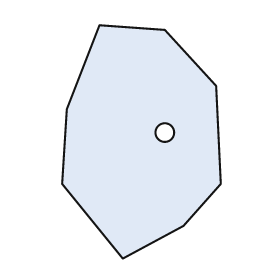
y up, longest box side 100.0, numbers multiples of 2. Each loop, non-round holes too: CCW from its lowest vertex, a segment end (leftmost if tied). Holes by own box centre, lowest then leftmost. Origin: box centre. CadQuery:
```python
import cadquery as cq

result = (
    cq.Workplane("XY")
    .moveTo(-8.0, -50.0)
    .lineTo(18.0, -36.0)
    .lineTo(34.0, -18.0)
    .lineTo(32.0, 24.0)
    .lineTo(10.0, 48.0)
    .lineTo(-18.0, 50.0)
    .lineTo(-32.0, 14.0)
    .lineTo(-34.0, -18.0)
    .close()
    .moveTo(10.0, 4.0)
    .circle(4.0)
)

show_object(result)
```